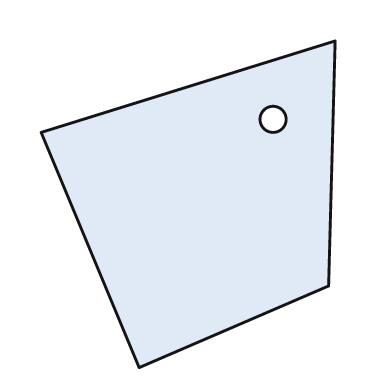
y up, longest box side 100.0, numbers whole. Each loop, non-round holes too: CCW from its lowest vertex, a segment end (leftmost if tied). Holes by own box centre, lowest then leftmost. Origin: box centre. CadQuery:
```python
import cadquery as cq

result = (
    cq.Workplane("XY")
    .moveTo(-15.0, -50.0)
    .lineTo(43.0, -25.0)
    .lineTo(45.0, 50.0)
    .lineTo(-45.0, 22.0)
    .close()
    .moveTo(26.0, 26.0)
    .circle(4.0)
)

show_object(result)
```